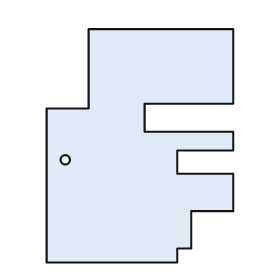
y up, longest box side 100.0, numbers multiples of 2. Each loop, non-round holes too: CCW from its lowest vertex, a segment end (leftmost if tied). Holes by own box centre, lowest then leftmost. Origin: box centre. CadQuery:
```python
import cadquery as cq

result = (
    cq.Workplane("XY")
    .moveTo(-40.0, -50.0)
    .lineTo(16.0, -50.0)
    .lineTo(16.0, -44.0)
    .lineTo(22.0, -44.0)
    .lineTo(22.0, -28.0)
    .lineTo(40.0, -28.0)
    .lineTo(40.0, -12.0)
    .lineTo(16.0, -12.0)
    .lineTo(16.0, -2.0)
    .lineTo(40.0, -2.0)
    .lineTo(40.0, 6.0)
    .lineTo(2.0, 6.0)
    .lineTo(2.0, 18.0)
    .lineTo(40.0, 18.0)
    .lineTo(40.0, 50.0)
    .lineTo(-22.0, 50.0)
    .lineTo(-22.0, 16.0)
    .lineTo(-40.0, 16.0)
    .close()
    .moveTo(-32.0, -6.0)
    .circle(2.0)
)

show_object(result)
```